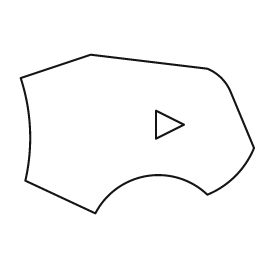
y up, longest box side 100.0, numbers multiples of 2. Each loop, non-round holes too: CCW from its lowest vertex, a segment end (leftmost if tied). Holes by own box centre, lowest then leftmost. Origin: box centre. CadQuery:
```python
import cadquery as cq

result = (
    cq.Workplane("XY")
    .moveTo(-18.0, -34.0)
    .threePointArc((4.0, -18.0), (30.0, -26.0))
    .threePointArc((42.0, -18.0), (50.0, -6.0))
    .lineTo(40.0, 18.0)
    .threePointArc((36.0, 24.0), (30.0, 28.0))
    .lineTo(-20.0, 34.0)
    .lineTo(-50.0, 24.0)
    .threePointArc((-46.0, 2.0), (-48.0, -20.0))
    .close()
    .moveTo(8.0, -2.0)
    .lineTo(20.0, 4.0)
    .lineTo(8.0, 10.0)
    .close()
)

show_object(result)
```